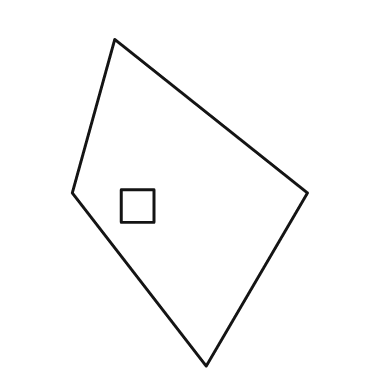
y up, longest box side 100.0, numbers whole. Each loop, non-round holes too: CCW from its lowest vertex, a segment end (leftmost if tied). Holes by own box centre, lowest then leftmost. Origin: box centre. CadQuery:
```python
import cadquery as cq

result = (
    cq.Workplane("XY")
    .moveTo(5.0, -50.0)
    .lineTo(36.0, 3.0)
    .lineTo(-23.0, 50.0)
    .lineTo(-36.0, 3.0)
    .close()
    .moveTo(-21.0, -6.0)
    .lineTo(-11.0, -6.0)
    .lineTo(-11.0, 4.0)
    .lineTo(-21.0, 4.0)
    .close()
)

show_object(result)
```